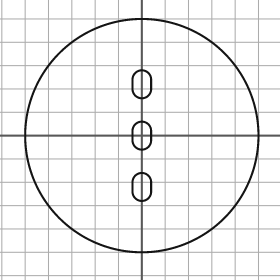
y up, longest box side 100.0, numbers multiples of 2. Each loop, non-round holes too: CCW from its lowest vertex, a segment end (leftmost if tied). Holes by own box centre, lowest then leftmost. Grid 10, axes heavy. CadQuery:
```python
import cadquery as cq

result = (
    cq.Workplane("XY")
    .moveTo(0.0, 0.0)
    .circle(50.0)
    .moveTo(-4.0, -24.0)
    .threePointArc((0.0, -28.0), (4.0, -24.0))
    .lineTo(4.0, -20.0)
    .threePointArc((0.0, -16.0), (-4.0, -20.0))
    .close()
    .moveTo(-4.0, -2.0)
    .threePointArc((0.0, -6.0), (4.0, -2.0))
    .lineTo(4.0, 2.0)
    .threePointArc((0.0, 6.0), (-4.0, 2.0))
    .close()
    .moveTo(-4.0, 20.0)
    .threePointArc((0.0, 16.0), (4.0, 20.0))
    .lineTo(4.0, 24.0)
    .threePointArc((0.0, 28.0), (-4.0, 24.0))
    .close()
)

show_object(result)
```